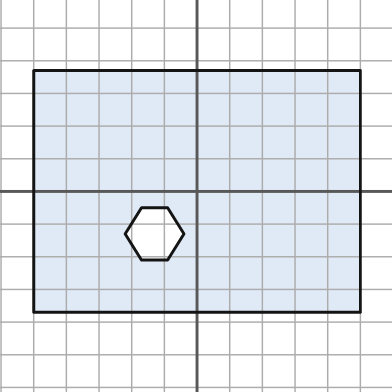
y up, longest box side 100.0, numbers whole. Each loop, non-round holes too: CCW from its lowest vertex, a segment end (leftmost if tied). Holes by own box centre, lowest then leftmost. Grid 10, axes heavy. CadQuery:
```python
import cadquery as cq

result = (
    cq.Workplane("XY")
    .moveTo(-50.0, -37.0)
    .lineTo(50.0, -37.0)
    .lineTo(50.0, 37.0)
    .lineTo(-50.0, 37.0)
    .close()
    .moveTo(-17.0, -21.0)
    .lineTo(-9.0, -21.0)
    .lineTo(-4.0, -13.0)
    .lineTo(-9.0, -5.0)
    .lineTo(-17.0, -5.0)
    .lineTo(-22.0, -13.0)
    .close()
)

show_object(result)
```